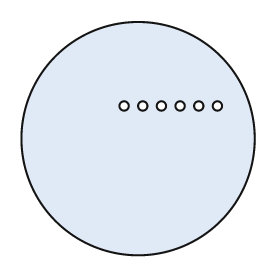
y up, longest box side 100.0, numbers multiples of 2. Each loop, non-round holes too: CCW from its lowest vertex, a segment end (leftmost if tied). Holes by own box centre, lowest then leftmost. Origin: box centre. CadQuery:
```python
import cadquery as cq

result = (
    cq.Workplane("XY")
    .moveTo(0.0, 0.0)
    .circle(50.0)
    .moveTo(-6.0, 14.0)
    .circle(2.0)
    .moveTo(2.0, 14.0)
    .circle(2.0)
    .moveTo(10.0, 14.0)
    .circle(2.0)
    .moveTo(18.0, 14.0)
    .circle(2.0)
    .moveTo(26.0, 14.0)
    .circle(2.0)
    .moveTo(34.0, 14.0)
    .circle(2.0)
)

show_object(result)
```